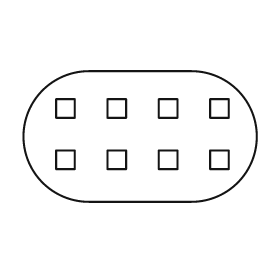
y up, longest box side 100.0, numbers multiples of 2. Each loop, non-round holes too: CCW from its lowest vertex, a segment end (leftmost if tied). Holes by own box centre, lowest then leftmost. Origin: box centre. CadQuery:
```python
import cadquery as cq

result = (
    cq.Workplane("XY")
    .moveTo(-22.0, -28.0)
    .lineTo(22.0, -28.0)
    .threePointArc((50.0, 0.0), (22.0, 28.0))
    .lineTo(-22.0, 28.0)
    .threePointArc((-50.0, 0.0), (-22.0, -28.0))
    .close()
    .moveTo(-36.0, -14.0)
    .lineTo(-28.0, -14.0)
    .lineTo(-28.0, -6.0)
    .lineTo(-36.0, -6.0)
    .close()
    .moveTo(-14.0, -14.0)
    .lineTo(-6.0, -14.0)
    .lineTo(-6.0, -6.0)
    .lineTo(-14.0, -6.0)
    .close()
    .moveTo(8.0, -14.0)
    .lineTo(16.0, -14.0)
    .lineTo(16.0, -6.0)
    .lineTo(8.0, -6.0)
    .close()
    .moveTo(30.0, -14.0)
    .lineTo(38.0, -14.0)
    .lineTo(38.0, -6.0)
    .lineTo(30.0, -6.0)
    .close()
    .moveTo(-36.0, 8.0)
    .lineTo(-28.0, 8.0)
    .lineTo(-28.0, 16.0)
    .lineTo(-36.0, 16.0)
    .close()
    .moveTo(-14.0, 8.0)
    .lineTo(-6.0, 8.0)
    .lineTo(-6.0, 16.0)
    .lineTo(-14.0, 16.0)
    .close()
    .moveTo(8.0, 8.0)
    .lineTo(16.0, 8.0)
    .lineTo(16.0, 16.0)
    .lineTo(8.0, 16.0)
    .close()
    .moveTo(30.0, 8.0)
    .lineTo(38.0, 8.0)
    .lineTo(38.0, 16.0)
    .lineTo(30.0, 16.0)
    .close()
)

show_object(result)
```